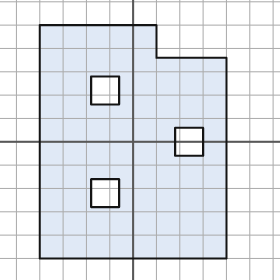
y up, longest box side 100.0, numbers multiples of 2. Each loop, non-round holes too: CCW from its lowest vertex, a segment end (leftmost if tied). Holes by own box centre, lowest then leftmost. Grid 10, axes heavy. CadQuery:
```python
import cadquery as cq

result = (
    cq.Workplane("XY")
    .moveTo(-40.0, -50.0)
    .lineTo(40.0, -50.0)
    .lineTo(40.0, 36.0)
    .lineTo(10.0, 36.0)
    .lineTo(10.0, 50.0)
    .lineTo(-40.0, 50.0)
    .close()
    .moveTo(-18.0, -28.0)
    .lineTo(-6.0, -28.0)
    .lineTo(-6.0, -16.0)
    .lineTo(-18.0, -16.0)
    .close()
    .moveTo(18.0, -6.0)
    .lineTo(30.0, -6.0)
    .lineTo(30.0, 6.0)
    .lineTo(18.0, 6.0)
    .close()
    .moveTo(-18.0, 16.0)
    .lineTo(-6.0, 16.0)
    .lineTo(-6.0, 28.0)
    .lineTo(-18.0, 28.0)
    .close()
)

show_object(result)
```